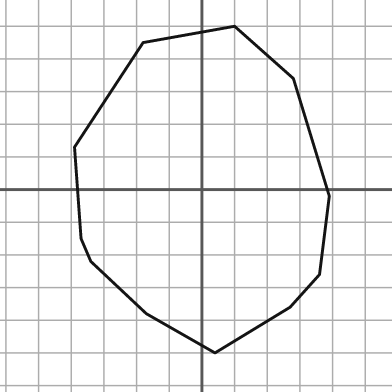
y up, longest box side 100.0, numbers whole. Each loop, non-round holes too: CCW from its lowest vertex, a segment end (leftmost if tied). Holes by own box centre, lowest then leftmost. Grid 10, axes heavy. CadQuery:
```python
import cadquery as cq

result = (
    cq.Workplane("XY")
    .moveTo(4.0, -50.0)
    .lineTo(27.0, -36.0)
    .lineTo(36.0, -26.0)
    .lineTo(39.0, -2.0)
    .lineTo(28.0, 34.0)
    .lineTo(10.0, 50.0)
    .lineTo(-18.0, 45.0)
    .lineTo(-39.0, 13.0)
    .lineTo(-37.0, -15.0)
    .lineTo(-34.0, -22.0)
    .lineTo(-17.0, -38.0)
    .close()
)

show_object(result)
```